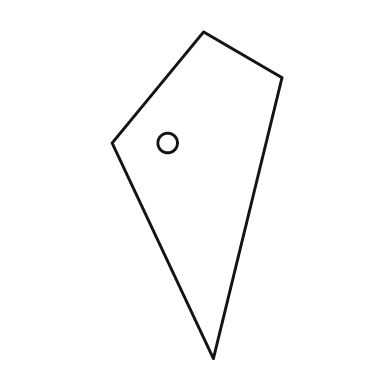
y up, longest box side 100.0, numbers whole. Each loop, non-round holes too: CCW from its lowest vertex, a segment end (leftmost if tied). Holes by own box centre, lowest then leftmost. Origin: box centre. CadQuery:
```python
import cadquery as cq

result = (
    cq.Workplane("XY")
    .moveTo(5.0, -50.0)
    .lineTo(26.0, 36.0)
    .lineTo(2.0, 50.0)
    .lineTo(-26.0, 16.0)
    .close()
    .moveTo(-9.0, 16.0)
    .circle(3.0)
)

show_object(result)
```